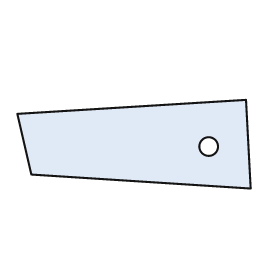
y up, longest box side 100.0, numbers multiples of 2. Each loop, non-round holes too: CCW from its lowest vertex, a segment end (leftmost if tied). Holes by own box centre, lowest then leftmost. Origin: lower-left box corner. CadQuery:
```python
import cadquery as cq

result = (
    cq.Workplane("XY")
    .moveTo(100.0, 0.0)
    .lineTo(98.0, 38.0)
    .lineTo(0.0, 32.0)
    .lineTo(6.0, 6.0)
    .close()
    .moveTo(82.0, 18.0)
    .circle(4.0)
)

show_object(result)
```